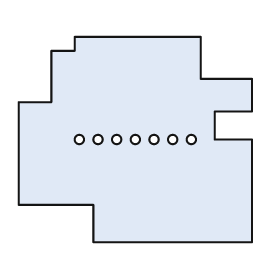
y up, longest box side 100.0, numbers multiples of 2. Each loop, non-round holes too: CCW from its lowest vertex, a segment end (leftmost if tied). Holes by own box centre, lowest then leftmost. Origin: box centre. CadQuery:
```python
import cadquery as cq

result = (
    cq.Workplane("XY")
    .moveTo(-18.0, -44.0)
    .lineTo(50.0, -44.0)
    .lineTo(50.0, 0.0)
    .lineTo(34.0, 0.0)
    .lineTo(34.0, 12.0)
    .lineTo(50.0, 12.0)
    .lineTo(50.0, 26.0)
    .lineTo(28.0, 26.0)
    .lineTo(28.0, 44.0)
    .lineTo(-26.0, 44.0)
    .lineTo(-26.0, 38.0)
    .lineTo(-36.0, 38.0)
    .lineTo(-36.0, 16.0)
    .lineTo(-50.0, 16.0)
    .lineTo(-50.0, -28.0)
    .lineTo(-18.0, -28.0)
    .close()
    .moveTo(-24.0, 0.0)
    .circle(2.0)
    .moveTo(-16.0, 0.0)
    .circle(2.0)
    .moveTo(-8.0, 0.0)
    .circle(2.0)
    .moveTo(0.0, 0.0)
    .circle(2.0)
    .moveTo(8.0, 0.0)
    .circle(2.0)
    .moveTo(16.0, 0.0)
    .circle(2.0)
    .moveTo(24.0, 0.0)
    .circle(2.0)
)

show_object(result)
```